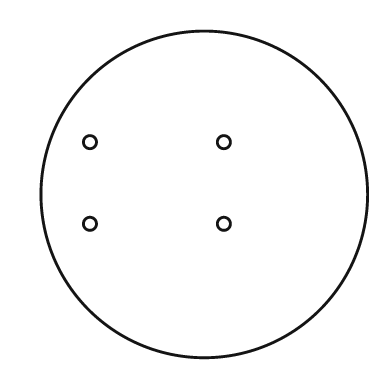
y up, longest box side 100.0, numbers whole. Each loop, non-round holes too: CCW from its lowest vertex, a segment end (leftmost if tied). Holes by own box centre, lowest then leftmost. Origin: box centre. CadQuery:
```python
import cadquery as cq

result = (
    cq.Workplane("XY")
    .moveTo(0.0, 0.0)
    .circle(50.0)
    .moveTo(-35.0, -9.0)
    .circle(2.0)
    .moveTo(6.0, -9.0)
    .circle(2.0)
    .moveTo(-35.0, 16.0)
    .circle(2.0)
    .moveTo(6.0, 16.0)
    .circle(2.0)
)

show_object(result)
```